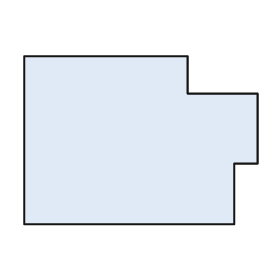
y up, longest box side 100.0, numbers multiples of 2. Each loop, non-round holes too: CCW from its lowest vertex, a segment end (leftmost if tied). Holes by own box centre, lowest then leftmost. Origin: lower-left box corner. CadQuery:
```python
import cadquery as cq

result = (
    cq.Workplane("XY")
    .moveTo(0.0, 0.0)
    .lineTo(90.0, 0.0)
    .lineTo(90.0, 26.0)
    .lineTo(100.0, 26.0)
    .lineTo(100.0, 56.0)
    .lineTo(70.0, 56.0)
    .lineTo(70.0, 72.0)
    .lineTo(0.0, 72.0)
    .close()
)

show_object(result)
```